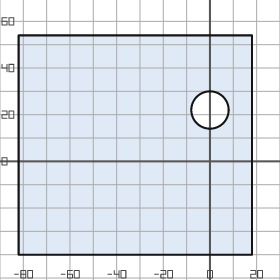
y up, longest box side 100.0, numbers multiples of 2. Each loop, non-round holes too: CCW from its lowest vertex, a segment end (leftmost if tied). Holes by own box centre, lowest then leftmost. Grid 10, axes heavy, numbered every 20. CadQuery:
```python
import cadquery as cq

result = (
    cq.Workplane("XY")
    .moveTo(-82.0, -40.0)
    .lineTo(18.0, -40.0)
    .lineTo(18.0, 54.0)
    .lineTo(-82.0, 54.0)
    .close()
    .moveTo(0.0, 22.0)
    .circle(8.0)
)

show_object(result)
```